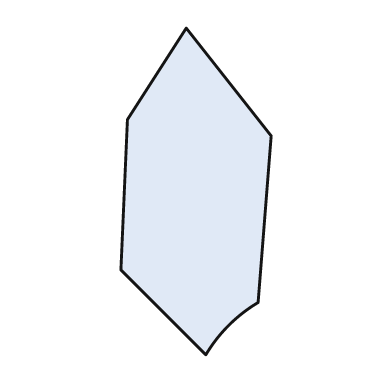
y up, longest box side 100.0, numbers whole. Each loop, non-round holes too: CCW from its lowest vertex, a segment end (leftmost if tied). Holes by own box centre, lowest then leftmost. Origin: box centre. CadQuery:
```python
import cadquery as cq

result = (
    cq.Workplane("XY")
    .moveTo(3.0, -50.0)
    .threePointArc((10.0, -41.0), (19.0, -34.0))
    .lineTo(23.0, 17.0)
    .lineTo(-3.0, 50.0)
    .lineTo(-21.0, 22.0)
    .lineTo(-23.0, -24.0)
    .close()
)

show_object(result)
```